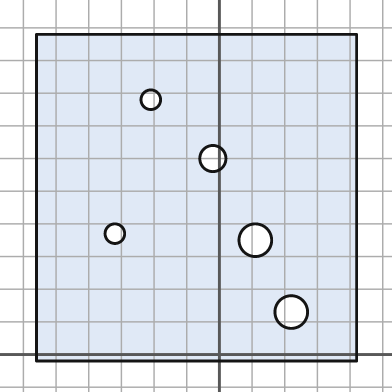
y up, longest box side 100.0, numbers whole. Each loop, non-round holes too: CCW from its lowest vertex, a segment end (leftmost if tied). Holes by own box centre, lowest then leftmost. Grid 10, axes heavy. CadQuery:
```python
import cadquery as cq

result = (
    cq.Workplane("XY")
    .moveTo(-56.0, -2.0)
    .lineTo(42.0, -2.0)
    .lineTo(42.0, 98.0)
    .lineTo(-56.0, 98.0)
    .close()
    .moveTo(22.0, 13.0)
    .circle(5.0)
    .moveTo(11.0, 35.0)
    .circle(5.0)
    .moveTo(-32.0, 37.0)
    .circle(3.0)
    .moveTo(-2.0, 60.0)
    .circle(4.0)
    .moveTo(-21.0, 78.0)
    .circle(3.0)
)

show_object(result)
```